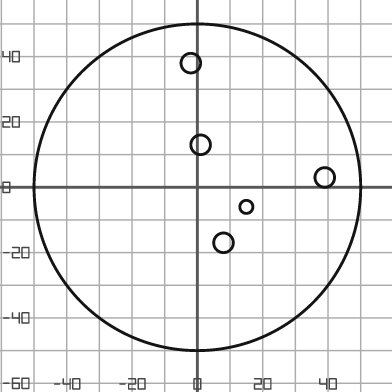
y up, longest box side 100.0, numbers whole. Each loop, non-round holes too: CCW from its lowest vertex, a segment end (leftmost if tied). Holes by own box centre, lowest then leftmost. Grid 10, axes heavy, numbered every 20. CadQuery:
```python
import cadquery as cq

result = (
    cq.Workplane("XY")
    .moveTo(0.0, 0.0)
    .circle(50.0)
    .moveTo(8.0, -17.0)
    .circle(3.0)
    .moveTo(15.0, -6.0)
    .circle(2.0)
    .moveTo(39.0, 3.0)
    .circle(3.0)
    .moveTo(1.0, 13.0)
    .circle(3.0)
    .moveTo(-2.0, 38.0)
    .circle(3.0)
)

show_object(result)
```